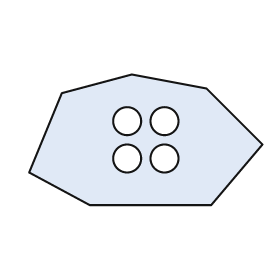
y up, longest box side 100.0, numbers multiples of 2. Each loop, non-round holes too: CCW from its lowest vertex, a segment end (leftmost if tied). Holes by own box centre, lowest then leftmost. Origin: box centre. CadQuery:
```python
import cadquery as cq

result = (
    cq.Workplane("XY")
    .moveTo(-24.0, -28.0)
    .lineTo(28.0, -28.0)
    .lineTo(50.0, -2.0)
    .lineTo(26.0, 22.0)
    .lineTo(-6.0, 28.0)
    .lineTo(-36.0, 20.0)
    .lineTo(-50.0, -14.0)
    .close()
    .moveTo(-8.0, -8.0)
    .circle(6.0)
    .moveTo(8.0, -8.0)
    .circle(6.0)
    .moveTo(-8.0, 8.0)
    .circle(6.0)
    .moveTo(8.0, 8.0)
    .circle(6.0)
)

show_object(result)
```